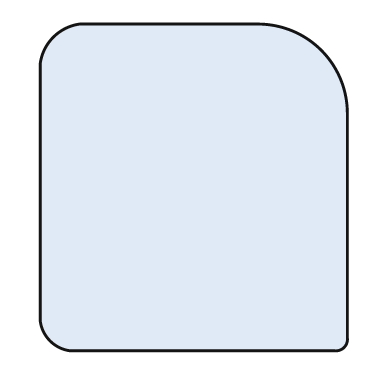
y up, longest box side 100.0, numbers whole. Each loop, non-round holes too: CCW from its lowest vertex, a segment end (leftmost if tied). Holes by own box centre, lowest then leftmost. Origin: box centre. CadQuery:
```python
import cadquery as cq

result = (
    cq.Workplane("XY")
    .moveTo(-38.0, -50.0)
    .lineTo(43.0, -50.0)
    .threePointArc((46.0, -49.0), (47.0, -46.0))
    .lineTo(47.0, 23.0)
    .threePointArc((39.0, 42.0), (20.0, 50.0))
    .lineTo(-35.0, 50.0)
    .threePointArc((-43.0, 46.0), (-47.0, 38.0))
    .lineTo(-47.0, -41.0)
    .threePointArc((-44.0, -47.0), (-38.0, -50.0))
    .close()
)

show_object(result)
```